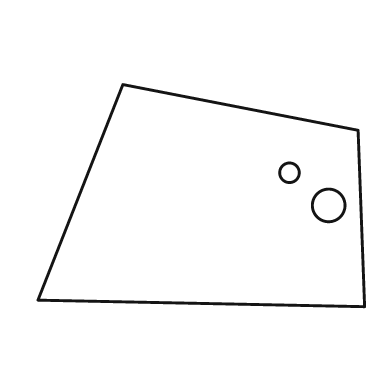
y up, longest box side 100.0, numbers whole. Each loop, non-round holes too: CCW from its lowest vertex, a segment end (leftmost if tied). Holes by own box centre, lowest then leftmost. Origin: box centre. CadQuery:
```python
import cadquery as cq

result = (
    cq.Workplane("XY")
    .moveTo(50.0, -34.0)
    .lineTo(48.0, 20.0)
    .lineTo(-24.0, 34.0)
    .lineTo(-50.0, -32.0)
    .close()
    .moveTo(39.0, -3.0)
    .circle(5.0)
    .moveTo(27.0, 7.0)
    .circle(3.0)
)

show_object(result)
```